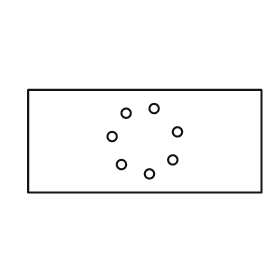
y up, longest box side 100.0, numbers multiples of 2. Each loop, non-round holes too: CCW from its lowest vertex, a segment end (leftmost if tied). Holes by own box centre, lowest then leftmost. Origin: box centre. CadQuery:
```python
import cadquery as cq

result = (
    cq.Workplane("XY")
    .moveTo(-50.0, -22.0)
    .lineTo(50.0, -22.0)
    .lineTo(50.0, 22.0)
    .lineTo(-50.0, 22.0)
    .close()
    .moveTo(2.0, -14.0)
    .circle(2.0)
    .moveTo(-10.0, -10.0)
    .circle(2.0)
    .moveTo(12.0, -8.0)
    .circle(2.0)
    .moveTo(-14.0, 2.0)
    .circle(2.0)
    .moveTo(14.0, 4.0)
    .circle(2.0)
    .moveTo(-8.0, 12.0)
    .circle(2.0)
    .moveTo(4.0, 14.0)
    .circle(2.0)
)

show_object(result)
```